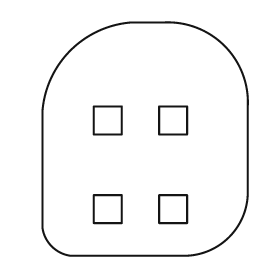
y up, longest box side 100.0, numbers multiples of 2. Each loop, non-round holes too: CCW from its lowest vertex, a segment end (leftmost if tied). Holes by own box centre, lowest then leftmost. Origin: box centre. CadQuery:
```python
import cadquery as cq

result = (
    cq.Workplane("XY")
    .moveTo(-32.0, -50.0)
    .lineTo(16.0, -50.0)
    .threePointArc((36.0, -42.0), (44.0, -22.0))
    .lineTo(44.0, 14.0)
    .threePointArc((34.0, 40.0), (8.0, 50.0))
    .lineTo(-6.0, 50.0)
    .threePointArc((-32.0, 38.0), (-44.0, 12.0))
    .lineTo(-44.0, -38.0)
    .threePointArc((-40.0, -46.0), (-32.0, -50.0))
    .close()
    .moveTo(-22.0, -36.0)
    .lineTo(-10.0, -36.0)
    .lineTo(-10.0, -24.0)
    .lineTo(-22.0, -24.0)
    .close()
    .moveTo(6.0, -36.0)
    .lineTo(18.0, -36.0)
    .lineTo(18.0, -24.0)
    .lineTo(6.0, -24.0)
    .close()
    .moveTo(-22.0, 2.0)
    .lineTo(-10.0, 2.0)
    .lineTo(-10.0, 14.0)
    .lineTo(-22.0, 14.0)
    .close()
    .moveTo(6.0, 2.0)
    .lineTo(18.0, 2.0)
    .lineTo(18.0, 14.0)
    .lineTo(6.0, 14.0)
    .close()
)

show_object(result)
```